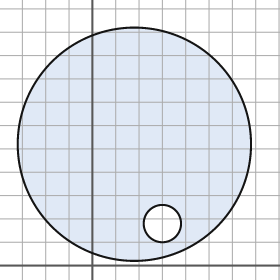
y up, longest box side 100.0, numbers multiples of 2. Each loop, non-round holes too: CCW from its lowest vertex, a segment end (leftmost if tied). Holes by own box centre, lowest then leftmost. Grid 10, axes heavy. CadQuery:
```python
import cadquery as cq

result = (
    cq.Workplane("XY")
    .moveTo(18.0, 52.0)
    .circle(50.0)
    .moveTo(30.0, 18.0)
    .circle(8.0)
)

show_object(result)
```